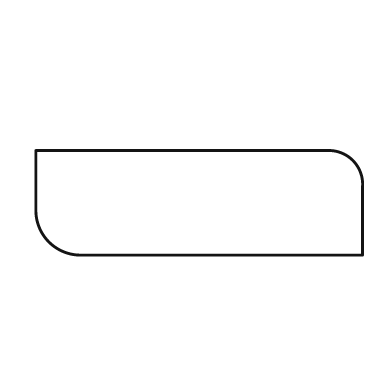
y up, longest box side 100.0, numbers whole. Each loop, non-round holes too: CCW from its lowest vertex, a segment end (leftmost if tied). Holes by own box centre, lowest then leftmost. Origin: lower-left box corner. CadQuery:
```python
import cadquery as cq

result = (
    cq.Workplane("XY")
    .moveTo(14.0, 0.0)
    .lineTo(100.0, 0.0)
    .lineTo(100.0, 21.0)
    .threePointArc((97.0, 29.0), (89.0, 32.0))
    .lineTo(0.0, 32.0)
    .lineTo(0.0, 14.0)
    .threePointArc((4.0, 4.0), (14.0, 0.0))
    .close()
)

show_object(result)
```